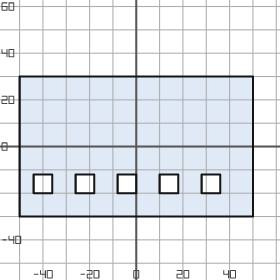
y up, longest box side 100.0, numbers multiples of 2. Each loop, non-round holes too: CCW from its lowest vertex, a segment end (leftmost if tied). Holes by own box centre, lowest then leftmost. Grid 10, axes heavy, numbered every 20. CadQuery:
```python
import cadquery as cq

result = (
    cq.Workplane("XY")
    .moveTo(-50.0, -30.0)
    .lineTo(50.0, -30.0)
    .lineTo(50.0, 30.0)
    .lineTo(-50.0, 30.0)
    .close()
    .moveTo(-44.0, -20.0)
    .lineTo(-36.0, -20.0)
    .lineTo(-36.0, -12.0)
    .lineTo(-44.0, -12.0)
    .close()
    .moveTo(-26.0, -20.0)
    .lineTo(-18.0, -20.0)
    .lineTo(-18.0, -12.0)
    .lineTo(-26.0, -12.0)
    .close()
    .moveTo(-8.0, -20.0)
    .lineTo(0.0, -20.0)
    .lineTo(0.0, -12.0)
    .lineTo(-8.0, -12.0)
    .close()
    .moveTo(10.0, -20.0)
    .lineTo(18.0, -20.0)
    .lineTo(18.0, -12.0)
    .lineTo(10.0, -12.0)
    .close()
    .moveTo(28.0, -20.0)
    .lineTo(36.0, -20.0)
    .lineTo(36.0, -12.0)
    .lineTo(28.0, -12.0)
    .close()
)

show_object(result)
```